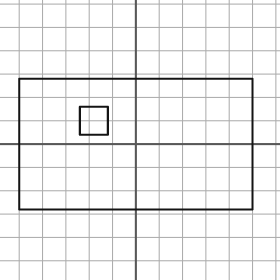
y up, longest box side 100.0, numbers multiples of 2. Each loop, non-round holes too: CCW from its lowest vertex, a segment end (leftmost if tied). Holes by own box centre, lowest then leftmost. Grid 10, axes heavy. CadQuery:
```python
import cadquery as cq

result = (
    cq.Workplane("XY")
    .moveTo(-50.0, -28.0)
    .lineTo(50.0, -28.0)
    .lineTo(50.0, 28.0)
    .lineTo(-50.0, 28.0)
    .close()
    .moveTo(-24.0, 4.0)
    .lineTo(-12.0, 4.0)
    .lineTo(-12.0, 16.0)
    .lineTo(-24.0, 16.0)
    .close()
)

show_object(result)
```